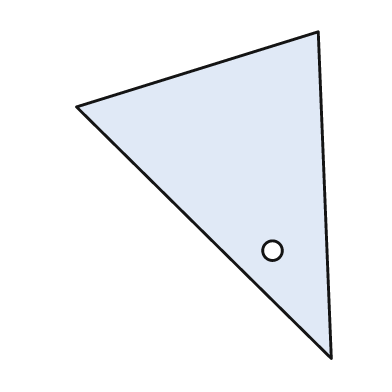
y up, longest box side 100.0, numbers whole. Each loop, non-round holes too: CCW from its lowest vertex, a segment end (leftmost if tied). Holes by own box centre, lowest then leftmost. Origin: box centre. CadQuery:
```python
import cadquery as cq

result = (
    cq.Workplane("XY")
    .moveTo(39.0, -50.0)
    .lineTo(35.0, 50.0)
    .lineTo(-39.0, 27.0)
    .close()
    .moveTo(21.0, -17.0)
    .circle(3.0)
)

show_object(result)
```